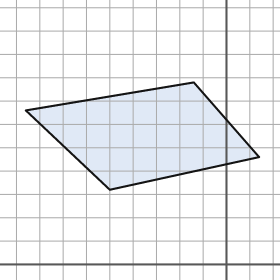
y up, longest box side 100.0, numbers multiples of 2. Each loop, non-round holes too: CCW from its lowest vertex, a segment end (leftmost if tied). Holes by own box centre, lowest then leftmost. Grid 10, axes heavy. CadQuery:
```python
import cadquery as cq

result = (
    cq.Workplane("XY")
    .moveTo(-50.0, 32.0)
    .lineTo(14.0, 46.0)
    .lineTo(-14.0, 78.0)
    .lineTo(-86.0, 66.0)
    .close()
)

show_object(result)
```